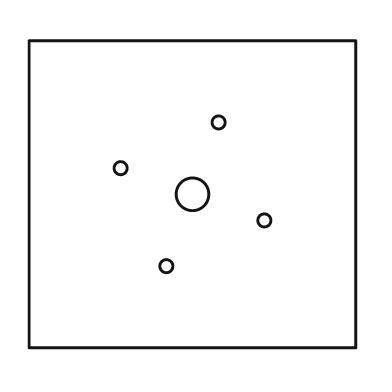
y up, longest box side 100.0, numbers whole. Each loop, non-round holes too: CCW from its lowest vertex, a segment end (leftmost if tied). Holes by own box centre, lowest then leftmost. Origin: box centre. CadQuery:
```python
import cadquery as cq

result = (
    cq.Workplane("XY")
    .moveTo(-50.0, -47.0)
    .lineTo(50.0, -47.0)
    .lineTo(50.0, 47.0)
    .lineTo(-50.0, 47.0)
    .close()
    .moveTo(-8.0, -22.0)
    .circle(2.0)
    .moveTo(22.0, -8.0)
    .circle(2.0)
    .moveTo(0.0, 0.0)
    .circle(5.0)
    .moveTo(-22.0, 8.0)
    .circle(2.0)
    .moveTo(8.0, 22.0)
    .circle(2.0)
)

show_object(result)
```